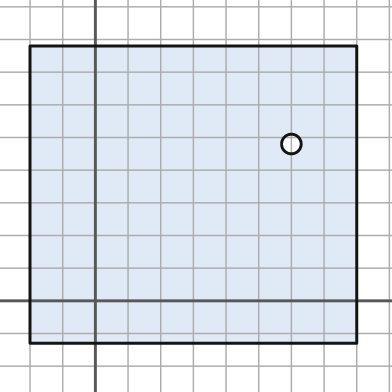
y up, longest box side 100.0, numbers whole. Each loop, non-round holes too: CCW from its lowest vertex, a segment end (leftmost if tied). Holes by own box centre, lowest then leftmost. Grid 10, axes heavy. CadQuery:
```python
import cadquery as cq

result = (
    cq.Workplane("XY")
    .moveTo(-20.0, -13.0)
    .lineTo(80.0, -13.0)
    .lineTo(80.0, 78.0)
    .lineTo(-20.0, 78.0)
    .close()
    .moveTo(60.0, 48.0)
    .circle(3.0)
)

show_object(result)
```